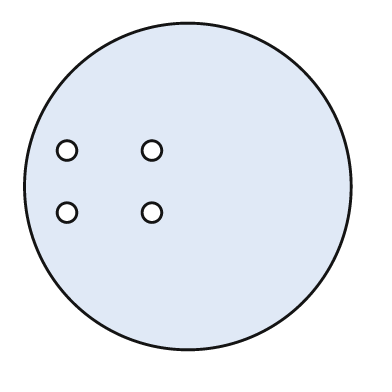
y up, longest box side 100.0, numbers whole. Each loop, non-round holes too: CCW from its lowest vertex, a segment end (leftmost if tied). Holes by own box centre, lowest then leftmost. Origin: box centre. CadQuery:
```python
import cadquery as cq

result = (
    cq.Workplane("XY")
    .moveTo(0.0, 0.0)
    .circle(50.0)
    .moveTo(-37.0, -8.0)
    .circle(3.0)
    .moveTo(-11.0, -8.0)
    .circle(3.0)
    .moveTo(-37.0, 11.0)
    .circle(3.0)
    .moveTo(-11.0, 11.0)
    .circle(3.0)
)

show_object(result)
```